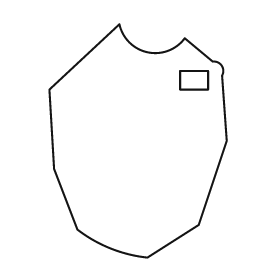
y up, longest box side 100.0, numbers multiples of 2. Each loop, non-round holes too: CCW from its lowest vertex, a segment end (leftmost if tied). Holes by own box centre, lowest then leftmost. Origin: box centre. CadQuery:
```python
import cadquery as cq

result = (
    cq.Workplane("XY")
    .moveTo(4.0, -50.0)
    .lineTo(26.0, -36.0)
    .lineTo(38.0, 0.0)
    .lineTo(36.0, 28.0)
    .threePointArc((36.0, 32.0), (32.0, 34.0))
    .lineTo(20.0, 44.0)
    .threePointArc((4.0, 38.0), (-8.0, 50.0))
    .lineTo(-38.0, 22.0)
    .lineTo(-36.0, -12.0)
    .lineTo(-26.0, -38.0)
    .threePointArc((-12.0, -46.0), (4.0, -50.0))
    .close()
    .moveTo(18.0, 22.0)
    .lineTo(30.0, 22.0)
    .lineTo(30.0, 30.0)
    .lineTo(18.0, 30.0)
    .close()
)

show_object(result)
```